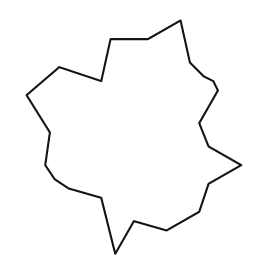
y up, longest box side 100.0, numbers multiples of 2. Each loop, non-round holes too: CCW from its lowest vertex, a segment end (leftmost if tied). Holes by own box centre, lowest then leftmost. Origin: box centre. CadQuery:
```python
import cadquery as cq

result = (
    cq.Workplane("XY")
    .moveTo(-8.0, -50.0)
    .lineTo(0.0, -36.0)
    .lineTo(14.0, -40.0)
    .lineTo(28.0, -32.0)
    .lineTo(32.0, -20.0)
    .lineTo(46.0, -12.0)
    .lineTo(32.0, -4.0)
    .lineTo(28.0, 6.0)
    .lineTo(36.0, 20.0)
    .lineTo(34.0, 24.0)
    .lineTo(30.0, 26.0)
    .lineTo(24.0, 32.0)
    .lineTo(20.0, 50.0)
    .lineTo(6.0, 42.0)
    .lineTo(-10.0, 42.0)
    .lineTo(-14.0, 24.0)
    .lineTo(-32.0, 30.0)
    .lineTo(-46.0, 18.0)
    .lineTo(-36.0, 2.0)
    .lineTo(-38.0, -12.0)
    .lineTo(-34.0, -18.0)
    .lineTo(-28.0, -22.0)
    .lineTo(-14.0, -26.0)
    .close()
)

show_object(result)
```